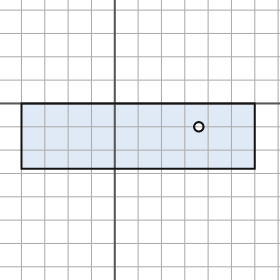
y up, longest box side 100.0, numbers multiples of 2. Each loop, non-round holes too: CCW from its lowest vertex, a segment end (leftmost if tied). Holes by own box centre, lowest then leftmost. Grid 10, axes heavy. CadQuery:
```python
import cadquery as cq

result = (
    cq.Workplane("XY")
    .moveTo(-40.0, -28.0)
    .lineTo(60.0, -28.0)
    .lineTo(60.0, 0.0)
    .lineTo(-40.0, 0.0)
    .close()
    .moveTo(36.0, -10.0)
    .circle(2.0)
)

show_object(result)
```